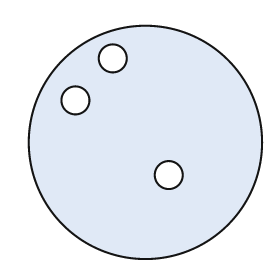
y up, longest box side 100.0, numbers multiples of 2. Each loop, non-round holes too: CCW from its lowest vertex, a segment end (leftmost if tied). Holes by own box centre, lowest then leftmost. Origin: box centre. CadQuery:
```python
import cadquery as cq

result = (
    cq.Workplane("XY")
    .moveTo(0.0, 0.0)
    .circle(50.0)
    .moveTo(10.0, -14.0)
    .circle(6.0)
    .moveTo(-30.0, 18.0)
    .circle(6.0)
    .moveTo(-14.0, 36.0)
    .circle(6.0)
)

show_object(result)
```